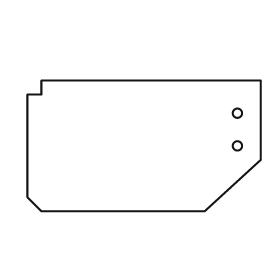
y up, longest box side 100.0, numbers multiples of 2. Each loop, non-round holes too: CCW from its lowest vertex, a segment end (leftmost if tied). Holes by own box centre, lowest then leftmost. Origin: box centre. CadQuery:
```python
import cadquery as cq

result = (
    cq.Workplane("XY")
    .moveTo(-44.0, -28.0)
    .lineTo(26.0, -28.0)
    .lineTo(50.0, -6.0)
    .lineTo(50.0, 28.0)
    .lineTo(-44.0, 28.0)
    .lineTo(-44.0, 22.0)
    .lineTo(-50.0, 22.0)
    .lineTo(-50.0, -22.0)
    .close()
    .moveTo(40.0, 0.0)
    .circle(2.0)
    .moveTo(40.0, 14.0)
    .circle(2.0)
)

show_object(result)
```